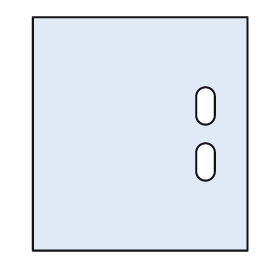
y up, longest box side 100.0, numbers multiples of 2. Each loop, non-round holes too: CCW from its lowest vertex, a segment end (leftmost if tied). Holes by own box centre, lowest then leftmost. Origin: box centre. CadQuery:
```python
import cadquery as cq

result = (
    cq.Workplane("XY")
    .moveTo(-46.0, -50.0)
    .lineTo(46.0, -50.0)
    .lineTo(46.0, 50.0)
    .lineTo(-46.0, 50.0)
    .close()
    .moveTo(24.0, -16.0)
    .threePointArc((28.0, -20.0), (32.0, -16.0))
    .lineTo(32.0, -8.0)
    .threePointArc((28.0, -4.0), (24.0, -8.0))
    .close()
    .moveTo(24.0, 8.0)
    .threePointArc((28.0, 4.0), (32.0, 8.0))
    .lineTo(32.0, 16.0)
    .threePointArc((28.0, 20.0), (24.0, 16.0))
    .close()
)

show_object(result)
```